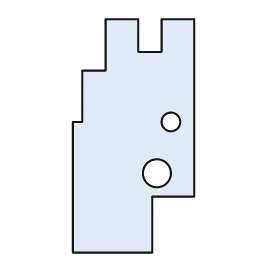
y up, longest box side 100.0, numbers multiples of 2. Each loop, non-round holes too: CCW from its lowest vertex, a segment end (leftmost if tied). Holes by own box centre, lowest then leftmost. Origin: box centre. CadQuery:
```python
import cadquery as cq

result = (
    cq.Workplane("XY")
    .moveTo(-26.0, -50.0)
    .lineTo(8.0, -50.0)
    .lineTo(8.0, -26.0)
    .lineTo(26.0, -26.0)
    .lineTo(26.0, 50.0)
    .lineTo(12.0, 50.0)
    .lineTo(12.0, 36.0)
    .lineTo(2.0, 36.0)
    .lineTo(2.0, 50.0)
    .lineTo(-12.0, 50.0)
    .lineTo(-12.0, 28.0)
    .lineTo(-22.0, 28.0)
    .lineTo(-22.0, 6.0)
    .lineTo(-26.0, 6.0)
    .close()
    .moveTo(10.0, -16.0)
    .circle(6.0)
    .moveTo(16.0, 6.0)
    .circle(4.0)
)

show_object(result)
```